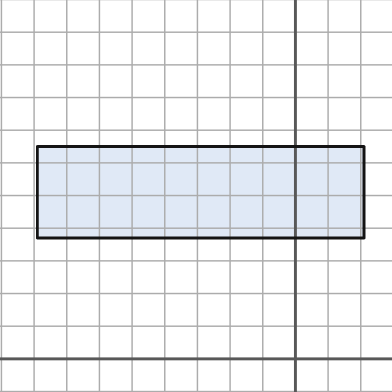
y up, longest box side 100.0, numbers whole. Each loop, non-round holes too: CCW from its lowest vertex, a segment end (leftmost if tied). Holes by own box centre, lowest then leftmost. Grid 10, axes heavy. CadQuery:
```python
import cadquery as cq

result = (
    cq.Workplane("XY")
    .moveTo(-79.0, 37.0)
    .lineTo(21.0, 37.0)
    .lineTo(21.0, 65.0)
    .lineTo(-79.0, 65.0)
    .close()
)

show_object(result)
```